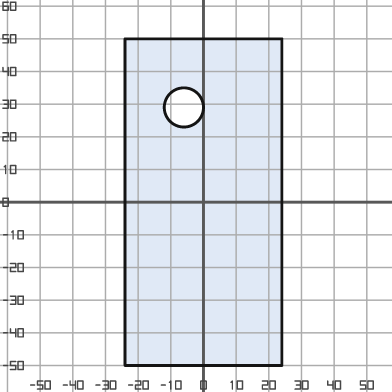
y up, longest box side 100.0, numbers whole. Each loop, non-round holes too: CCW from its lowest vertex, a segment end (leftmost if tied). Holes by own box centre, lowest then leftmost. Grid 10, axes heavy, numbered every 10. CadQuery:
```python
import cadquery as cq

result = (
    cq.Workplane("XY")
    .moveTo(-24.0, -50.0)
    .lineTo(24.0, -50.0)
    .lineTo(24.0, 50.0)
    .lineTo(-24.0, 50.0)
    .close()
    .moveTo(-6.0, 29.0)
    .circle(6.0)
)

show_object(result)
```